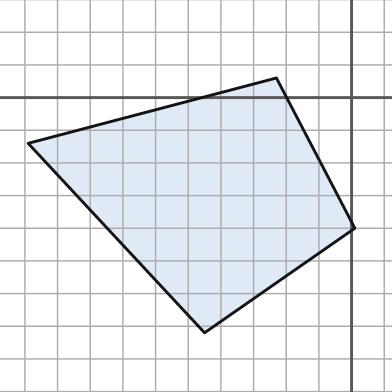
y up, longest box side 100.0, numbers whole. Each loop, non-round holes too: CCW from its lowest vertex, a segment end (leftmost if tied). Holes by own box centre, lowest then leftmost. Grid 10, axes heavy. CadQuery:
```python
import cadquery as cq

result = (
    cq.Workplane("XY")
    .moveTo(-45.0, -72.0)
    .lineTo(1.0, -40.0)
    .lineTo(-23.0, 6.0)
    .lineTo(-99.0, -14.0)
    .close()
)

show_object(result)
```